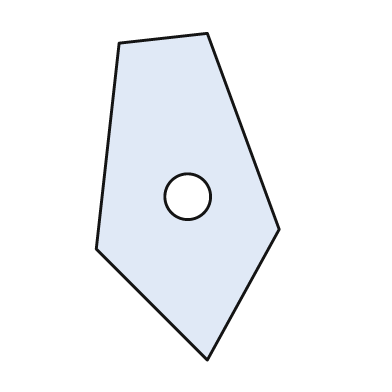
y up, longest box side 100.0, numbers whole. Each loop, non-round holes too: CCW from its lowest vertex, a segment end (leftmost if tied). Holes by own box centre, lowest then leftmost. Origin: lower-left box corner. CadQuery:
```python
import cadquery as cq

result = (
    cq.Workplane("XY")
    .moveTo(34.0, 0.0)
    .lineTo(56.0, 40.0)
    .lineTo(34.0, 100.0)
    .lineTo(7.0, 97.0)
    .lineTo(0.0, 34.0)
    .close()
    .moveTo(28.0, 50.0)
    .circle(7.0)
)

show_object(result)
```